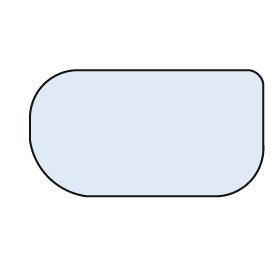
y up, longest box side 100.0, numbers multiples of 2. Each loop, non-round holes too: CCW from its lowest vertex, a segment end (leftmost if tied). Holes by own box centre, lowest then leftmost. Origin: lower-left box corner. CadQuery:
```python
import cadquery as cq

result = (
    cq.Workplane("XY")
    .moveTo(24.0, 0.0)
    .lineTo(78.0, 0.0)
    .threePointArc((94.0, 6.0), (100.0, 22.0))
    .lineTo(100.0, 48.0)
    .threePointArc((98.0, 52.0), (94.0, 54.0))
    .lineTo(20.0, 54.0)
    .threePointArc((6.0, 48.0), (0.0, 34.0))
    .lineTo(0.0, 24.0)
    .threePointArc((8.0, 8.0), (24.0, 0.0))
    .close()
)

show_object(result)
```